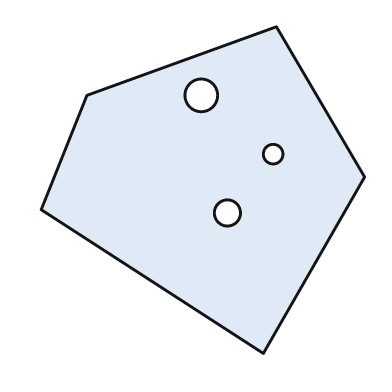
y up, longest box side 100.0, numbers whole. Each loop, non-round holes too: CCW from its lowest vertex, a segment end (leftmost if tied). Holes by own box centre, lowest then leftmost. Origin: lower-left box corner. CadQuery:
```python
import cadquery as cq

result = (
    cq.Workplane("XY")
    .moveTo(68.0, 0.0)
    .lineTo(99.0, 54.0)
    .lineTo(72.0, 100.0)
    .lineTo(14.0, 79.0)
    .lineTo(0.0, 44.0)
    .close()
    .moveTo(57.0, 43.0)
    .circle(4.0)
    .moveTo(71.0, 61.0)
    .circle(3.0)
    .moveTo(49.0, 79.0)
    .circle(5.0)
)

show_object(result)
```